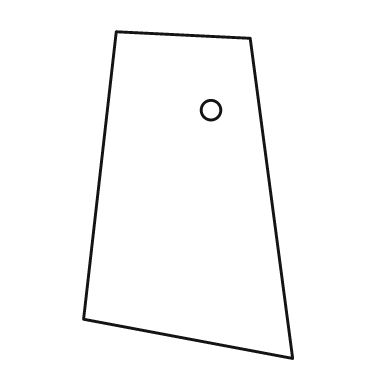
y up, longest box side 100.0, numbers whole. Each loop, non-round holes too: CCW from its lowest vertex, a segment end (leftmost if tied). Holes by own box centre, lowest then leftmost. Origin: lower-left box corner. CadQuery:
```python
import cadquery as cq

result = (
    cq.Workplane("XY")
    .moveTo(64.0, 0.0)
    .lineTo(51.0, 98.0)
    .lineTo(10.0, 100.0)
    .lineTo(0.0, 12.0)
    .close()
    .moveTo(39.0, 76.0)
    .circle(3.0)
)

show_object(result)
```